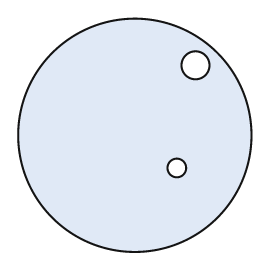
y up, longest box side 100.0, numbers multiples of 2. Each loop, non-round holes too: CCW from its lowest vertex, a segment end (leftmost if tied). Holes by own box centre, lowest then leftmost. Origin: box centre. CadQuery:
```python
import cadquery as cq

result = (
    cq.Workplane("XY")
    .moveTo(0.0, 0.0)
    .circle(50.0)
    .moveTo(18.0, -14.0)
    .circle(4.0)
    .moveTo(26.0, 30.0)
    .circle(6.0)
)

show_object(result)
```